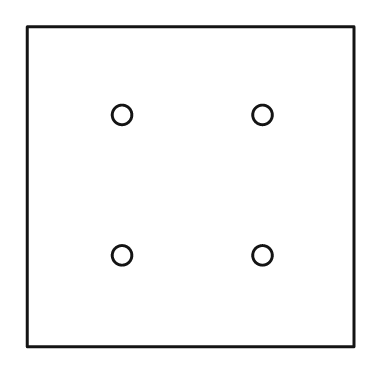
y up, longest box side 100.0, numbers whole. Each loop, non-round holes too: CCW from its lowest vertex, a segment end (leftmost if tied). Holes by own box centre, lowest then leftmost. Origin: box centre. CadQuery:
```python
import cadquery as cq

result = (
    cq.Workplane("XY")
    .moveTo(-50.0, -49.0)
    .lineTo(50.0, -49.0)
    .lineTo(50.0, 49.0)
    .lineTo(-50.0, 49.0)
    .close()
    .moveTo(-21.0, -21.0)
    .circle(3.0)
    .moveTo(22.0, -21.0)
    .circle(3.0)
    .moveTo(-21.0, 22.0)
    .circle(3.0)
    .moveTo(22.0, 22.0)
    .circle(3.0)
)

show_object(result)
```